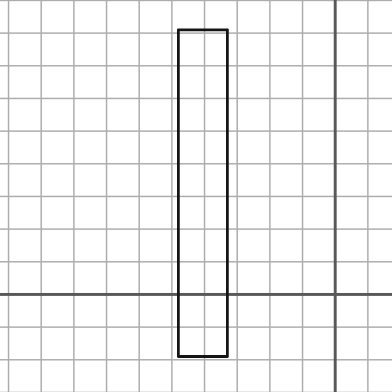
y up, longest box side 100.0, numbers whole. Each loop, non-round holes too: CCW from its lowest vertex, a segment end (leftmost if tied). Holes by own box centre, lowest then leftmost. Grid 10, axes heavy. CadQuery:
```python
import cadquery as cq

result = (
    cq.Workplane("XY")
    .moveTo(-48.0, -19.0)
    .lineTo(-33.0, -19.0)
    .lineTo(-33.0, 81.0)
    .lineTo(-48.0, 81.0)
    .close()
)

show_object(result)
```